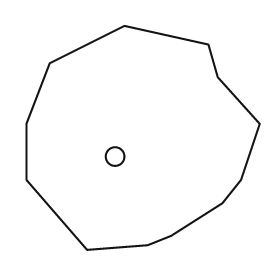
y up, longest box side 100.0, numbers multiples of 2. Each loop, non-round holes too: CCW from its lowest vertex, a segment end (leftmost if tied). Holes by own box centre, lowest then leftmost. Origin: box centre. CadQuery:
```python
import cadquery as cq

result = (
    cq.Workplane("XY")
    .moveTo(-24.0, -48.0)
    .lineTo(2.0, -46.0)
    .lineTo(12.0, -42.0)
    .lineTo(34.0, -28.0)
    .lineTo(42.0, -18.0)
    .lineTo(50.0, 6.0)
    .lineTo(32.0, 26.0)
    .lineTo(28.0, 40.0)
    .lineTo(-8.0, 48.0)
    .lineTo(-40.0, 32.0)
    .lineTo(-50.0, 6.0)
    .lineTo(-50.0, -18.0)
    .close()
    .moveTo(-12.0, -8.0)
    .circle(4.0)
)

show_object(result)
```